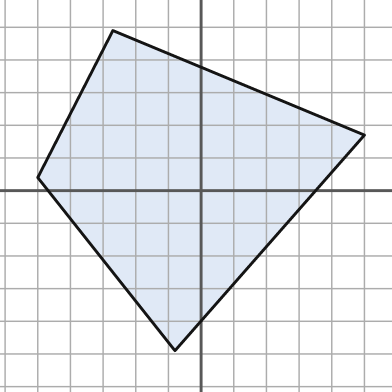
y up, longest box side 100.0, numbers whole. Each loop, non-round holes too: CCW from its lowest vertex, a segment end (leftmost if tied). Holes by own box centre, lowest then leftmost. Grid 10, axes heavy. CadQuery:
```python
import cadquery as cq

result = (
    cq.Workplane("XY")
    .moveTo(-8.0, -49.0)
    .lineTo(50.0, 17.0)
    .lineTo(-27.0, 49.0)
    .lineTo(-50.0, 4.0)
    .close()
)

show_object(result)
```